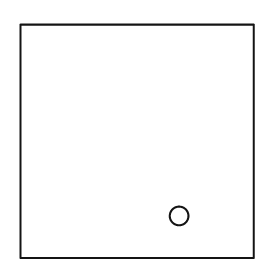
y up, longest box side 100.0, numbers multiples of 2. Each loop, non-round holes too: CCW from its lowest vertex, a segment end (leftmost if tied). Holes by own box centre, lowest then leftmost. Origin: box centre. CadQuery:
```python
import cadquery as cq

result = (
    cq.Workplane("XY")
    .moveTo(-50.0, -50.0)
    .lineTo(50.0, -50.0)
    .lineTo(50.0, 50.0)
    .lineTo(-50.0, 50.0)
    .close()
    .moveTo(18.0, -32.0)
    .circle(4.0)
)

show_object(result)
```